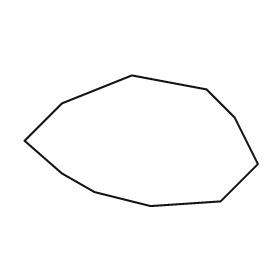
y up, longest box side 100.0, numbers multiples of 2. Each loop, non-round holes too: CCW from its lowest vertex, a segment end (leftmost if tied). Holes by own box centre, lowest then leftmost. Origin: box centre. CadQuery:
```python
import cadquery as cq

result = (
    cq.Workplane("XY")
    .moveTo(4.0, -28.0)
    .lineTo(34.0, -26.0)
    .lineTo(50.0, -10.0)
    .lineTo(40.0, 10.0)
    .lineTo(28.0, 22.0)
    .lineTo(-4.0, 28.0)
    .lineTo(-34.0, 16.0)
    .lineTo(-50.0, 0.0)
    .lineTo(-34.0, -14.0)
    .lineTo(-20.0, -22.0)
    .close()
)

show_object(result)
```